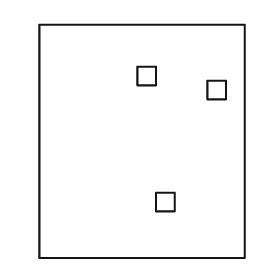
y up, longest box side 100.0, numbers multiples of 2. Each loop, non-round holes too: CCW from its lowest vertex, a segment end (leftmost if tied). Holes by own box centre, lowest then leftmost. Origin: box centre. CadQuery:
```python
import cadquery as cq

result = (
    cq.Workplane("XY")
    .moveTo(-44.0, -50.0)
    .lineTo(44.0, -50.0)
    .lineTo(44.0, 50.0)
    .lineTo(-44.0, 50.0)
    .close()
    .moveTo(6.0, -30.0)
    .lineTo(14.0, -30.0)
    .lineTo(14.0, -22.0)
    .lineTo(6.0, -22.0)
    .close()
    .moveTo(28.0, 18.0)
    .lineTo(36.0, 18.0)
    .lineTo(36.0, 26.0)
    .lineTo(28.0, 26.0)
    .close()
    .moveTo(-2.0, 24.0)
    .lineTo(6.0, 24.0)
    .lineTo(6.0, 32.0)
    .lineTo(-2.0, 32.0)
    .close()
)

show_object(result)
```